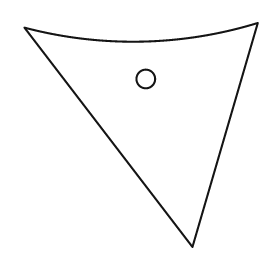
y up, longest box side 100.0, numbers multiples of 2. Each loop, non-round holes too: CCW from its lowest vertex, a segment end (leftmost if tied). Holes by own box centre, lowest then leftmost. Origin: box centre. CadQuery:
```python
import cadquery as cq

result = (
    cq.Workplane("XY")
    .moveTo(22.0, -48.0)
    .lineTo(50.0, 48.0)
    .threePointArc((0.0, 40.0), (-50.0, 46.0))
    .close()
    .moveTo(2.0, 24.0)
    .circle(4.0)
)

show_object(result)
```